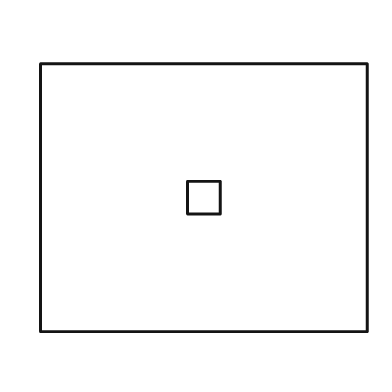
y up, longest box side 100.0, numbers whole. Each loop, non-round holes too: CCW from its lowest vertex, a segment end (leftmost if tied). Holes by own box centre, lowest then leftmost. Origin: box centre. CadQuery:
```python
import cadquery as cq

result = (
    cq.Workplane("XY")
    .moveTo(-50.0, -41.0)
    .lineTo(50.0, -41.0)
    .lineTo(50.0, 41.0)
    .lineTo(-50.0, 41.0)
    .close()
    .moveTo(-5.0, -5.0)
    .lineTo(5.0, -5.0)
    .lineTo(5.0, 5.0)
    .lineTo(-5.0, 5.0)
    .close()
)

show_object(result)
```